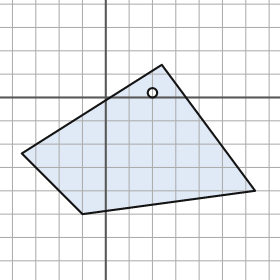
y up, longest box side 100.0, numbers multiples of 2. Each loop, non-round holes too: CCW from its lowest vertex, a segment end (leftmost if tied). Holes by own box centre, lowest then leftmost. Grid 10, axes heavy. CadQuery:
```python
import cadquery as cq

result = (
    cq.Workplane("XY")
    .moveTo(-10.0, -50.0)
    .lineTo(64.0, -40.0)
    .lineTo(24.0, 14.0)
    .lineTo(-36.0, -24.0)
    .close()
    .moveTo(20.0, 2.0)
    .circle(2.0)
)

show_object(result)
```